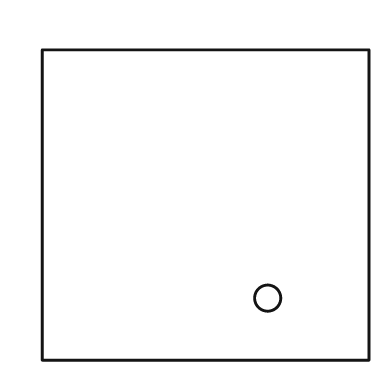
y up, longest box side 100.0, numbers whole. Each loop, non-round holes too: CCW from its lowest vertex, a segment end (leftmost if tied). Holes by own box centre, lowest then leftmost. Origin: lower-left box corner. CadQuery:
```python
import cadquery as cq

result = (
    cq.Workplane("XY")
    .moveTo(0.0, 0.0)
    .lineTo(100.0, 0.0)
    .lineTo(100.0, 95.0)
    .lineTo(0.0, 95.0)
    .close()
    .moveTo(69.0, 19.0)
    .circle(4.0)
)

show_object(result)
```